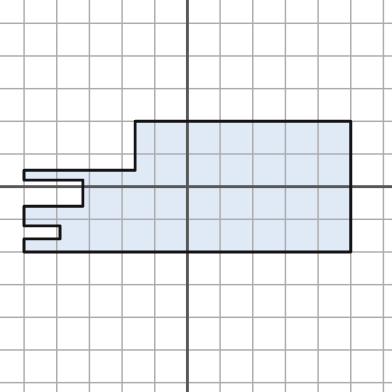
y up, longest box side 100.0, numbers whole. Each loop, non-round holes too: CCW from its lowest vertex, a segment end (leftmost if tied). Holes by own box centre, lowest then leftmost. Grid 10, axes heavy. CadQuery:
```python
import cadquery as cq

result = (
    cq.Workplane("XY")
    .moveTo(-50.0, -20.0)
    .lineTo(50.0, -20.0)
    .lineTo(50.0, 20.0)
    .lineTo(-16.0, 20.0)
    .lineTo(-16.0, 5.0)
    .lineTo(-50.0, 5.0)
    .lineTo(-50.0, 2.0)
    .lineTo(-32.0, 2.0)
    .lineTo(-32.0, -6.0)
    .lineTo(-50.0, -6.0)
    .lineTo(-50.0, -12.0)
    .lineTo(-39.0, -12.0)
    .lineTo(-39.0, -16.0)
    .lineTo(-50.0, -16.0)
    .close()
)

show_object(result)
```